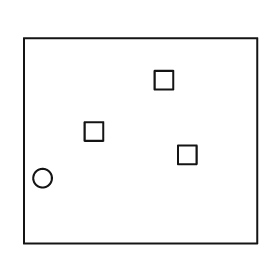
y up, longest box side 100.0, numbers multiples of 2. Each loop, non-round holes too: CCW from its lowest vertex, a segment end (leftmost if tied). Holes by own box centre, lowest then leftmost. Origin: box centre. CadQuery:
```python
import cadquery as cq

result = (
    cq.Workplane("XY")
    .moveTo(-50.0, -44.0)
    .lineTo(50.0, -44.0)
    .lineTo(50.0, 44.0)
    .lineTo(-50.0, 44.0)
    .close()
    .moveTo(-42.0, -16.0)
    .circle(4.0)
    .moveTo(16.0, -10.0)
    .lineTo(24.0, -10.0)
    .lineTo(24.0, -2.0)
    .lineTo(16.0, -2.0)
    .close()
    .moveTo(-24.0, 0.0)
    .lineTo(-16.0, 0.0)
    .lineTo(-16.0, 8.0)
    .lineTo(-24.0, 8.0)
    .close()
    .moveTo(6.0, 22.0)
    .lineTo(14.0, 22.0)
    .lineTo(14.0, 30.0)
    .lineTo(6.0, 30.0)
    .close()
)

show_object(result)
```